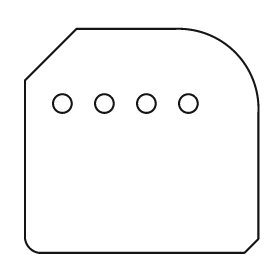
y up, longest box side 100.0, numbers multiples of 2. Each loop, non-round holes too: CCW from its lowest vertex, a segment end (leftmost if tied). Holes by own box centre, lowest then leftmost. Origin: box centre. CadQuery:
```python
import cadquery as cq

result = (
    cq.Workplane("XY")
    .moveTo(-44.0, -48.0)
    .lineTo(44.0, -48.0)
    .lineTo(50.0, -42.0)
    .lineTo(50.0, 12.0)
    .threePointArc((40.0, 38.0), (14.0, 48.0))
    .lineTo(-28.0, 48.0)
    .lineTo(-50.0, 26.0)
    .lineTo(-50.0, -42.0)
    .threePointArc((-48.0, -46.0), (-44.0, -48.0))
    .close()
    .moveTo(-34.0, 16.0)
    .circle(4.0)
    .moveTo(-16.0, 16.0)
    .circle(4.0)
    .moveTo(2.0, 16.0)
    .circle(4.0)
    .moveTo(20.0, 16.0)
    .circle(4.0)
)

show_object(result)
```